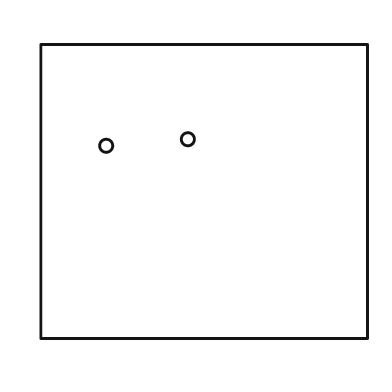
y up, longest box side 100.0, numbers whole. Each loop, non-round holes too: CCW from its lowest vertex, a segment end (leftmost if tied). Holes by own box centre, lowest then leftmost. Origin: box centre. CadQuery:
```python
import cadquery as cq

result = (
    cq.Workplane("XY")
    .moveTo(-50.0, -45.0)
    .lineTo(50.0, -45.0)
    .lineTo(50.0, 45.0)
    .lineTo(-50.0, 45.0)
    .close()
    .moveTo(-30.0, 14.0)
    .circle(2.0)
    .moveTo(-5.0, 16.0)
    .circle(2.0)
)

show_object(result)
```